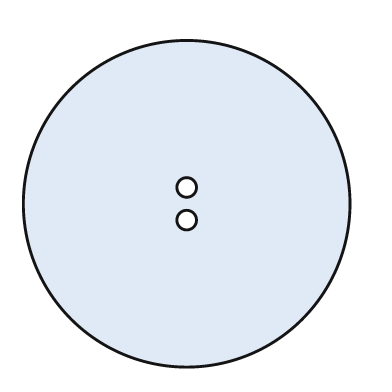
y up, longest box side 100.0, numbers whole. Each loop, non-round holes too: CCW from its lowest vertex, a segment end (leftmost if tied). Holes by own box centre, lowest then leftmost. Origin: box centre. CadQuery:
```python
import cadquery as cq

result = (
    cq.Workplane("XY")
    .moveTo(0.0, 0.0)
    .circle(50.0)
    .moveTo(0.0, -5.0)
    .circle(3.0)
    .moveTo(0.0, 5.0)
    .circle(3.0)
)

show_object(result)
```